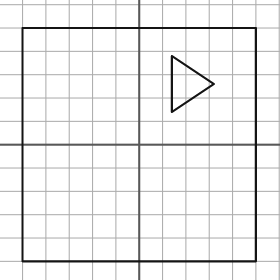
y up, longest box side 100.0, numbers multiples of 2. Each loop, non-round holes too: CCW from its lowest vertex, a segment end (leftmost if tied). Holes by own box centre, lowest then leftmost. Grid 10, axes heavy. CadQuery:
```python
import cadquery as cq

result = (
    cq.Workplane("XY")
    .moveTo(-50.0, -50.0)
    .lineTo(50.0, -50.0)
    .lineTo(50.0, 50.0)
    .lineTo(-50.0, 50.0)
    .close()
    .moveTo(14.0, 14.0)
    .lineTo(32.0, 26.0)
    .lineTo(14.0, 38.0)
    .close()
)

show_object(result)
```